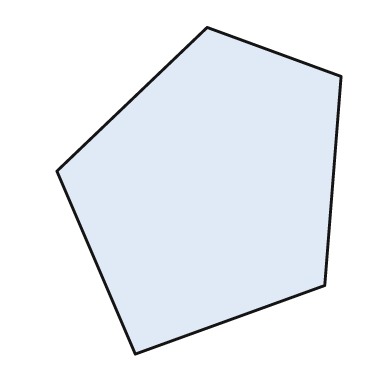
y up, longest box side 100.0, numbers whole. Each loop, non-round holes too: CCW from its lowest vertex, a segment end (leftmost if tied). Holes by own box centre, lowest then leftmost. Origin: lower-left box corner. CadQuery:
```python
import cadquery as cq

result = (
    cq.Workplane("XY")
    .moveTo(24.0, 0.0)
    .lineTo(82.0, 21.0)
    .lineTo(87.0, 85.0)
    .lineTo(46.0, 100.0)
    .lineTo(0.0, 56.0)
    .close()
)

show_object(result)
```